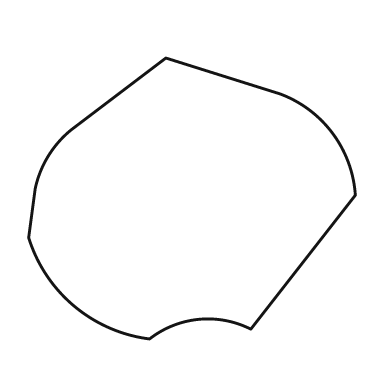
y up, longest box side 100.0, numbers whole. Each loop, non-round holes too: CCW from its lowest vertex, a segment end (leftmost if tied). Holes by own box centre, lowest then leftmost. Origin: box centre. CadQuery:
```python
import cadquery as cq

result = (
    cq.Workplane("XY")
    .moveTo(-13.0, -43.0)
    .threePointArc((2.0, -37.0), (18.0, -40.0))
    .lineTo(50.0, 1.0)
    .threePointArc((43.0, 20.0), (27.0, 32.0))
    .lineTo(-8.0, 43.0)
    .lineTo(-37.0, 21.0)
    .threePointArc((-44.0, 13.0), (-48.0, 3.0))
    .lineTo(-50.0, -12.0)
    .threePointArc((-36.0, -33.0), (-13.0, -43.0))
    .close()
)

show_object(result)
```